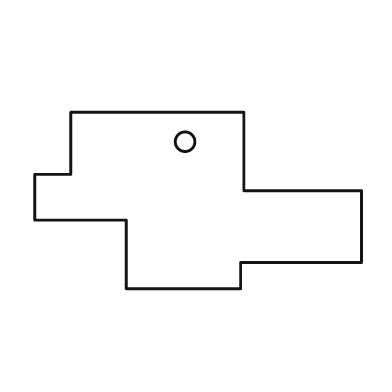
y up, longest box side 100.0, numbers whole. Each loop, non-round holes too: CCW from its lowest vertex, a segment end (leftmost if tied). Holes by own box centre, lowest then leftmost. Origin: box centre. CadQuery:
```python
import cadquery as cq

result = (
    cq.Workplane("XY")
    .moveTo(-22.0, -27.0)
    .lineTo(13.0, -27.0)
    .lineTo(13.0, -19.0)
    .lineTo(50.0, -19.0)
    .lineTo(50.0, 3.0)
    .lineTo(14.0, 3.0)
    .lineTo(14.0, 27.0)
    .lineTo(-39.0, 27.0)
    .lineTo(-39.0, 8.0)
    .lineTo(-50.0, 8.0)
    .lineTo(-50.0, -6.0)
    .lineTo(-22.0, -6.0)
    .close()
    .moveTo(-4.0, 18.0)
    .circle(3.0)
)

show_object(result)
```